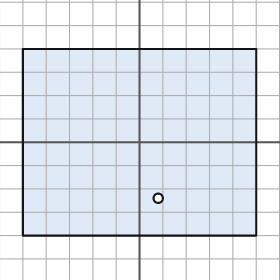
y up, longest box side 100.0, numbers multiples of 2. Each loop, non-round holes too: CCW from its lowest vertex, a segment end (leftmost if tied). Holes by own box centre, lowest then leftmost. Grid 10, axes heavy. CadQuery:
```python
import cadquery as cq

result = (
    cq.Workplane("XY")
    .moveTo(-50.0, -40.0)
    .lineTo(50.0, -40.0)
    .lineTo(50.0, 40.0)
    .lineTo(-50.0, 40.0)
    .close()
    .moveTo(8.0, -24.0)
    .circle(2.0)
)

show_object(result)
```